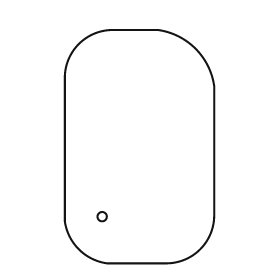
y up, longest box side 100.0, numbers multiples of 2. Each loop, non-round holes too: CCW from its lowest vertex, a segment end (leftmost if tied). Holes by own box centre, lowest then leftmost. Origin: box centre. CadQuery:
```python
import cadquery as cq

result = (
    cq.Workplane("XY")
    .moveTo(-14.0, -50.0)
    .lineTo(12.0, -50.0)
    .threePointArc((26.0, -44.0), (32.0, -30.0))
    .lineTo(32.0, 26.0)
    .threePointArc((24.0, 42.0), (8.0, 50.0))
    .lineTo(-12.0, 50.0)
    .threePointArc((-26.0, 44.0), (-32.0, 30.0))
    .lineTo(-32.0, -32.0)
    .threePointArc((-26.0, -44.0), (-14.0, -50.0))
    .close()
    .moveTo(-16.0, -30.0)
    .circle(2.0)
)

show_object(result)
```